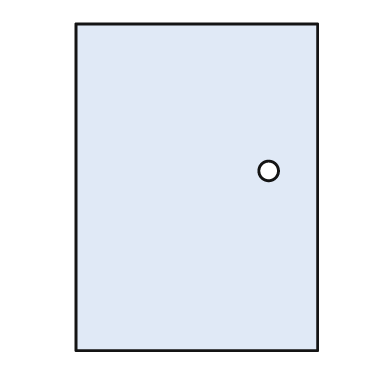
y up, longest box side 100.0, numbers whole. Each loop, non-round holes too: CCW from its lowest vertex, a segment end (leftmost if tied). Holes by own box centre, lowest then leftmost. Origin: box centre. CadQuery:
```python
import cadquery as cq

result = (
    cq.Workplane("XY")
    .moveTo(-37.0, -50.0)
    .lineTo(37.0, -50.0)
    .lineTo(37.0, 50.0)
    .lineTo(-37.0, 50.0)
    .close()
    .moveTo(22.0, 5.0)
    .circle(3.0)
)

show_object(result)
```